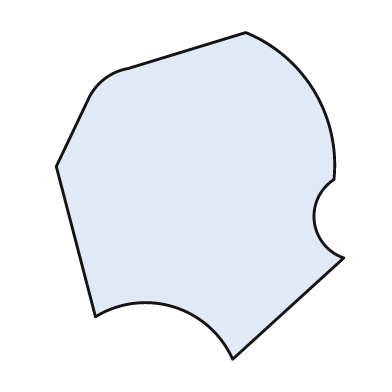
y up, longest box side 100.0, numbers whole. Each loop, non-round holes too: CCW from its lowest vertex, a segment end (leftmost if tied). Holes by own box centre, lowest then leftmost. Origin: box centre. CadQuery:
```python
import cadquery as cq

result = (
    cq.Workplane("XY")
    .moveTo(10.0, -50.0)
    .lineTo(44.0, -19.0)
    .threePointArc((35.0, -8.0), (41.0, 5.0))
    .threePointArc((35.0, 32.0), (14.0, 50.0))
    .lineTo(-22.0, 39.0)
    .threePointArc((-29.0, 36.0), (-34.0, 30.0))
    .lineTo(-44.0, 9.0)
    .lineTo(-32.0, -37.0)
    .threePointArc((-8.0, -34.0), (10.0, -50.0))
    .close()
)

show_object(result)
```